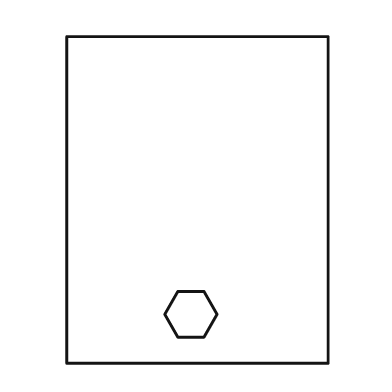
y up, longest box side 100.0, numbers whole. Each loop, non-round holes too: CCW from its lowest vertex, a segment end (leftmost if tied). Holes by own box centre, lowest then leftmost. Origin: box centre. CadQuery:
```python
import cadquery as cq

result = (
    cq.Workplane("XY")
    .moveTo(-40.0, -50.0)
    .lineTo(40.0, -50.0)
    .lineTo(40.0, 50.0)
    .lineTo(-40.0, 50.0)
    .close()
    .moveTo(-6.0, -42.0)
    .lineTo(2.0, -42.0)
    .lineTo(6.0, -35.0)
    .lineTo(2.0, -28.0)
    .lineTo(-6.0, -28.0)
    .lineTo(-10.0, -35.0)
    .close()
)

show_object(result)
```